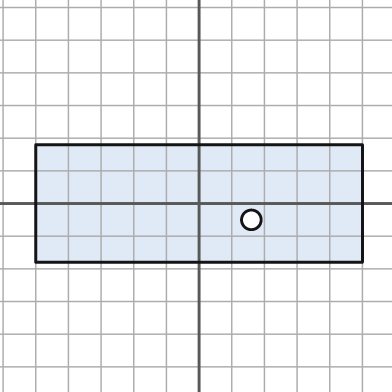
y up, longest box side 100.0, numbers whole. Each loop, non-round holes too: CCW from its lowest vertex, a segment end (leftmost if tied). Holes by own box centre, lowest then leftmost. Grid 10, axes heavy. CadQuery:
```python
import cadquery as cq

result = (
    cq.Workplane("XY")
    .moveTo(-50.0, -18.0)
    .lineTo(50.0, -18.0)
    .lineTo(50.0, 18.0)
    .lineTo(-50.0, 18.0)
    .close()
    .moveTo(16.0, -5.0)
    .circle(3.0)
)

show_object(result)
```